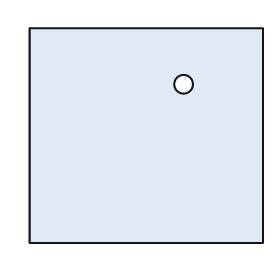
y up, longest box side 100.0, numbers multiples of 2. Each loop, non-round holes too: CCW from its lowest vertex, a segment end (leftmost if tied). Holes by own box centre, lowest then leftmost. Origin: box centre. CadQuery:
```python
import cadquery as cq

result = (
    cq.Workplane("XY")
    .moveTo(-50.0, -46.0)
    .lineTo(50.0, -46.0)
    .lineTo(50.0, 46.0)
    .lineTo(-50.0, 46.0)
    .close()
    .moveTo(16.0, 22.0)
    .circle(4.0)
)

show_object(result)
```